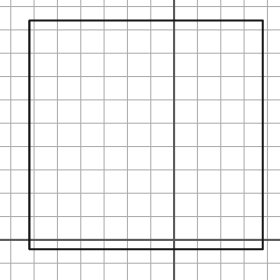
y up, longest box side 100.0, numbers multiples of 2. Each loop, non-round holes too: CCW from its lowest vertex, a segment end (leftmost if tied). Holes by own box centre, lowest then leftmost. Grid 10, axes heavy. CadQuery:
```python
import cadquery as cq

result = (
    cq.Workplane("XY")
    .moveTo(-62.0, -4.0)
    .lineTo(38.0, -4.0)
    .lineTo(38.0, 94.0)
    .lineTo(-62.0, 94.0)
    .close()
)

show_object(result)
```